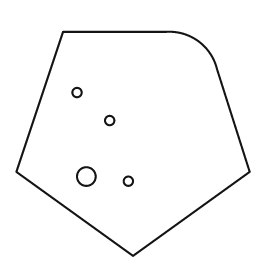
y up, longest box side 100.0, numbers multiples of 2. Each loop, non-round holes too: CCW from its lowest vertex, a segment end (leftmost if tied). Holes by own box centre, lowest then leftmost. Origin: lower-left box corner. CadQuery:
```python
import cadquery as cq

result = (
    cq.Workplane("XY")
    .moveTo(50.0, 0.0)
    .lineTo(100.0, 36.0)
    .lineTo(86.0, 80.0)
    .threePointArc((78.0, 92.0), (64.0, 96.0))
    .lineTo(20.0, 96.0)
    .lineTo(0.0, 36.0)
    .close()
    .moveTo(48.0, 32.0)
    .circle(2.0)
    .moveTo(30.0, 34.0)
    .circle(4.0)
    .moveTo(40.0, 58.0)
    .circle(2.0)
    .moveTo(26.0, 70.0)
    .circle(2.0)
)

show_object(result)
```